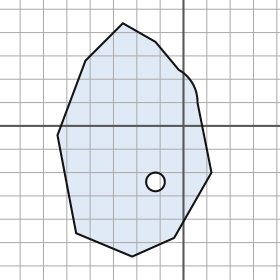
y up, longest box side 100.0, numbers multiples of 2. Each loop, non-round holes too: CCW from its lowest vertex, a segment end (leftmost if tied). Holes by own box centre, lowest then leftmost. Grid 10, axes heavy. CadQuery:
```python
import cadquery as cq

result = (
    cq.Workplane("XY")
    .moveTo(-22.0, -56.0)
    .lineTo(-4.0, -48.0)
    .lineTo(12.0, -20.0)
    .lineTo(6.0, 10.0)
    .threePointArc((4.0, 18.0), (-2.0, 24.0))
    .lineTo(-12.0, 36.0)
    .lineTo(-26.0, 44.0)
    .lineTo(-42.0, 28.0)
    .lineTo(-54.0, -4.0)
    .lineTo(-46.0, -46.0)
    .close()
    .moveTo(-12.0, -24.0)
    .circle(4.0)
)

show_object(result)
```